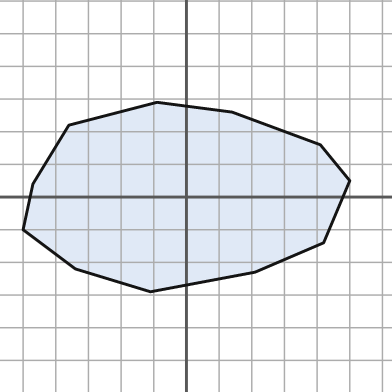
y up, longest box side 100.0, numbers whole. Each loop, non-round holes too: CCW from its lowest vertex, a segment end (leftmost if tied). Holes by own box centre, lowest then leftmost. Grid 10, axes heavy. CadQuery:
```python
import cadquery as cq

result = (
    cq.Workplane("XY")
    .moveTo(-11.0, -29.0)
    .lineTo(21.0, -23.0)
    .lineTo(42.0, -14.0)
    .lineTo(50.0, 5.0)
    .lineTo(41.0, 16.0)
    .lineTo(14.0, 26.0)
    .lineTo(-9.0, 29.0)
    .lineTo(-36.0, 22.0)
    .lineTo(-47.0, 4.0)
    .lineTo(-50.0, -10.0)
    .lineTo(-34.0, -22.0)
    .close()
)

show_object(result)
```